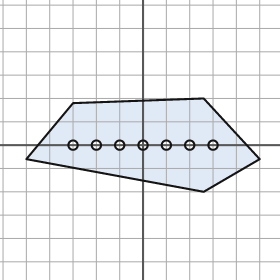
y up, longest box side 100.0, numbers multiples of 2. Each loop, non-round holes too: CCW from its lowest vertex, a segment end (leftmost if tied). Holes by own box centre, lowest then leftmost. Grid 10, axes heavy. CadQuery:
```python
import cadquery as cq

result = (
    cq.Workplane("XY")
    .moveTo(26.0, -20.0)
    .lineTo(50.0, -6.0)
    .lineTo(26.0, 20.0)
    .lineTo(-30.0, 18.0)
    .lineTo(-50.0, -6.0)
    .close()
    .moveTo(-30.0, 0.0)
    .circle(2.0)
    .moveTo(-20.0, 0.0)
    .circle(2.0)
    .moveTo(-10.0, 0.0)
    .circle(2.0)
    .moveTo(0.0, 0.0)
    .circle(2.0)
    .moveTo(10.0, 0.0)
    .circle(2.0)
    .moveTo(20.0, 0.0)
    .circle(2.0)
    .moveTo(30.0, 0.0)
    .circle(2.0)
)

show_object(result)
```